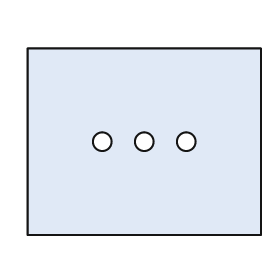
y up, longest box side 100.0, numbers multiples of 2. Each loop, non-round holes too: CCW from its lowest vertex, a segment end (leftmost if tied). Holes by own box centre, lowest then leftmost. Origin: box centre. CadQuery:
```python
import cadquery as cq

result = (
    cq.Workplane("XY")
    .moveTo(-50.0, -40.0)
    .lineTo(50.0, -40.0)
    .lineTo(50.0, 40.0)
    .lineTo(-50.0, 40.0)
    .close()
    .moveTo(-18.0, 0.0)
    .circle(4.0)
    .moveTo(0.0, 0.0)
    .circle(4.0)
    .moveTo(18.0, 0.0)
    .circle(4.0)
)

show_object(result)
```